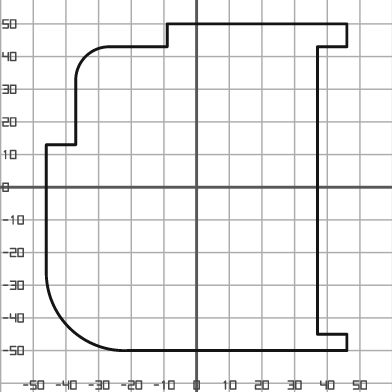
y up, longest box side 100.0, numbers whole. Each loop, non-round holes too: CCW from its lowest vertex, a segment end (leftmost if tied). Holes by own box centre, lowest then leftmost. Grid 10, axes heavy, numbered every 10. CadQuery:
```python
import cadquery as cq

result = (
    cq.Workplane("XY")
    .moveTo(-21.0, -50.0)
    .lineTo(46.0, -50.0)
    .lineTo(46.0, -45.0)
    .lineTo(37.0, -45.0)
    .lineTo(37.0, 43.0)
    .lineTo(46.0, 43.0)
    .lineTo(46.0, 50.0)
    .lineTo(-9.0, 50.0)
    .lineTo(-9.0, 43.0)
    .lineTo(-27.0, 43.0)
    .threePointArc((-34.0, 40.0), (-37.0, 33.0))
    .lineTo(-37.0, 13.0)
    .lineTo(-46.0, 13.0)
    .lineTo(-46.0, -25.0)
    .threePointArc((-39.0, -43.0), (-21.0, -50.0))
    .close()
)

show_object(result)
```